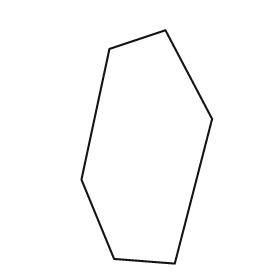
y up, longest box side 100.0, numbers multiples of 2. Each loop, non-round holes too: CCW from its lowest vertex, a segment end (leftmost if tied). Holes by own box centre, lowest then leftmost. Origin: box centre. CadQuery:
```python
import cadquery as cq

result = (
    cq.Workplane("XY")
    .moveTo(12.0, -50.0)
    .lineTo(28.0, 12.0)
    .lineTo(8.0, 50.0)
    .lineTo(-16.0, 42.0)
    .lineTo(-28.0, -14.0)
    .lineTo(-14.0, -48.0)
    .close()
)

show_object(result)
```